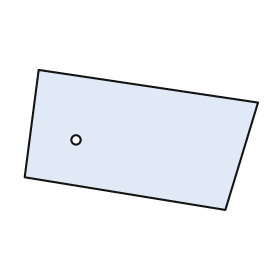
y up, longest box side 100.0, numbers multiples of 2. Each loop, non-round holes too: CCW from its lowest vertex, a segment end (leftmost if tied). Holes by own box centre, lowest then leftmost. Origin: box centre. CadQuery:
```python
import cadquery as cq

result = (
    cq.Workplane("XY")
    .moveTo(36.0, -30.0)
    .lineTo(50.0, 16.0)
    .lineTo(-44.0, 30.0)
    .lineTo(-50.0, -16.0)
    .close()
    .moveTo(-28.0, 0.0)
    .circle(2.0)
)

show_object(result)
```